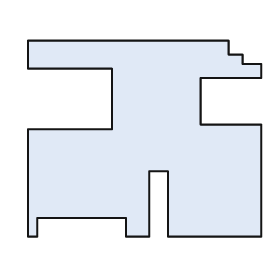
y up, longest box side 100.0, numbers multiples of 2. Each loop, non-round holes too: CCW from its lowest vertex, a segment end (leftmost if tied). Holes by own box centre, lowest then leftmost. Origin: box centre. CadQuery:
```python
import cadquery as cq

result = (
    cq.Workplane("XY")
    .moveTo(-50.0, -42.0)
    .lineTo(-46.0, -42.0)
    .lineTo(-46.0, -34.0)
    .lineTo(-8.0, -34.0)
    .lineTo(-8.0, -42.0)
    .lineTo(2.0, -42.0)
    .lineTo(2.0, -14.0)
    .lineTo(10.0, -14.0)
    .lineTo(10.0, -42.0)
    .lineTo(50.0, -42.0)
    .lineTo(50.0, 6.0)
    .lineTo(24.0, 6.0)
    .lineTo(24.0, 26.0)
    .lineTo(50.0, 26.0)
    .lineTo(50.0, 32.0)
    .lineTo(42.0, 32.0)
    .lineTo(42.0, 36.0)
    .lineTo(36.0, 36.0)
    .lineTo(36.0, 42.0)
    .lineTo(-50.0, 42.0)
    .lineTo(-50.0, 30.0)
    .lineTo(-14.0, 30.0)
    .lineTo(-14.0, 4.0)
    .lineTo(-50.0, 4.0)
    .close()
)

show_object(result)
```